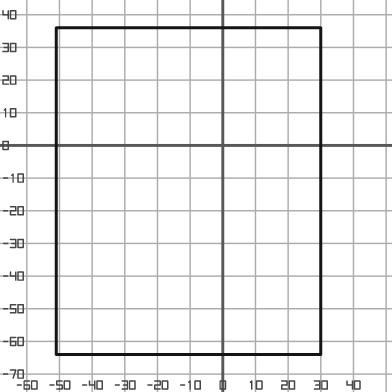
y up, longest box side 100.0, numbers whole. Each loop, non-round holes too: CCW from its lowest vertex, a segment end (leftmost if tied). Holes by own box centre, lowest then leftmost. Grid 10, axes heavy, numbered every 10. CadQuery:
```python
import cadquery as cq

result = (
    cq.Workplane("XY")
    .moveTo(-51.0, -64.0)
    .lineTo(30.0, -64.0)
    .lineTo(30.0, 36.0)
    .lineTo(-51.0, 36.0)
    .close()
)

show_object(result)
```